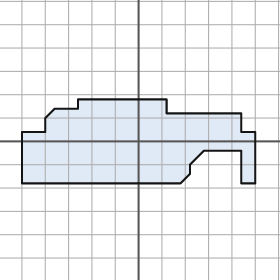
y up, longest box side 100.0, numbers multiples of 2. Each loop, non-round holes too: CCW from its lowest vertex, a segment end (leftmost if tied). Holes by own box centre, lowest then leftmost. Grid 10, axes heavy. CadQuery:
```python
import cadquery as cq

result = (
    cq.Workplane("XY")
    .moveTo(-50.0, -18.0)
    .lineTo(18.0, -18.0)
    .lineTo(22.0, -14.0)
    .lineTo(22.0, -10.0)
    .lineTo(28.0, -4.0)
    .lineTo(44.0, -4.0)
    .lineTo(44.0, -18.0)
    .lineTo(50.0, -18.0)
    .lineTo(50.0, 4.0)
    .lineTo(44.0, 4.0)
    .lineTo(44.0, 12.0)
    .lineTo(12.0, 12.0)
    .lineTo(12.0, 18.0)
    .lineTo(-26.0, 18.0)
    .lineTo(-26.0, 14.0)
    .lineTo(-36.0, 14.0)
    .lineTo(-40.0, 10.0)
    .lineTo(-40.0, 4.0)
    .lineTo(-50.0, 4.0)
    .close()
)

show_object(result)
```